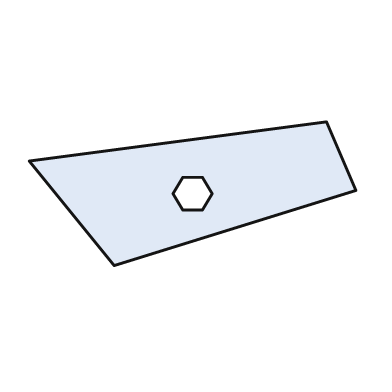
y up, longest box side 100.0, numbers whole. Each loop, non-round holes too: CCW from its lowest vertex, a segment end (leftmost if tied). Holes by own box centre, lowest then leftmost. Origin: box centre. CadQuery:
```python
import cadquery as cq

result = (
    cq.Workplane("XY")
    .moveTo(-24.0, -22.0)
    .lineTo(50.0, 1.0)
    .lineTo(41.0, 22.0)
    .lineTo(-50.0, 10.0)
    .close()
    .moveTo(-3.0, -5.0)
    .lineTo(3.0, -5.0)
    .lineTo(6.0, 0.0)
    .lineTo(3.0, 5.0)
    .lineTo(-3.0, 5.0)
    .lineTo(-6.0, 0.0)
    .close()
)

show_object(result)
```